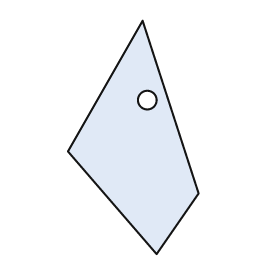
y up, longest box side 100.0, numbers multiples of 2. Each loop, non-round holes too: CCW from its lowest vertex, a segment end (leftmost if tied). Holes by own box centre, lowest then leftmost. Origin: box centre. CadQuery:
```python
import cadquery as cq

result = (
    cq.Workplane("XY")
    .moveTo(10.0, -50.0)
    .lineTo(28.0, -24.0)
    .lineTo(4.0, 50.0)
    .lineTo(-28.0, -6.0)
    .close()
    .moveTo(6.0, 16.0)
    .circle(4.0)
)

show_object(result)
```